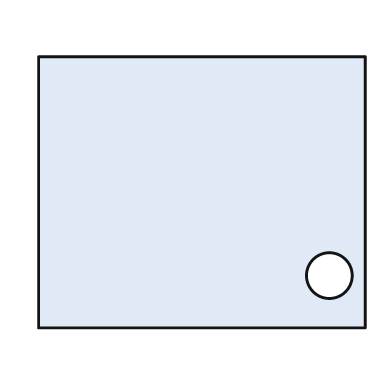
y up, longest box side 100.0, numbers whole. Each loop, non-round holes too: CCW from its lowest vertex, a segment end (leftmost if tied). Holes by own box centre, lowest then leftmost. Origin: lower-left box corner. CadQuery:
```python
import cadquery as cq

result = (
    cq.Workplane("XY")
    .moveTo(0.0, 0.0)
    .lineTo(100.0, 0.0)
    .lineTo(100.0, 83.0)
    .lineTo(0.0, 83.0)
    .close()
    .moveTo(89.0, 16.0)
    .circle(7.0)
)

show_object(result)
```